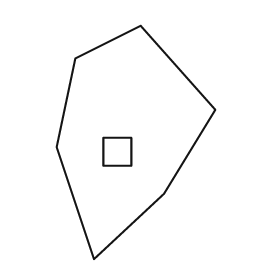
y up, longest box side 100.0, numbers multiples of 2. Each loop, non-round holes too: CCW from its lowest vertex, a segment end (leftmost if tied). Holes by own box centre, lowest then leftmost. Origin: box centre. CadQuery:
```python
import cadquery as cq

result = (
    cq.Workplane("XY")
    .moveTo(-18.0, -50.0)
    .lineTo(12.0, -22.0)
    .lineTo(34.0, 14.0)
    .lineTo(2.0, 50.0)
    .lineTo(-26.0, 36.0)
    .lineTo(-34.0, -2.0)
    .close()
    .moveTo(-14.0, -10.0)
    .lineTo(-2.0, -10.0)
    .lineTo(-2.0, 2.0)
    .lineTo(-14.0, 2.0)
    .close()
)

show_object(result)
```